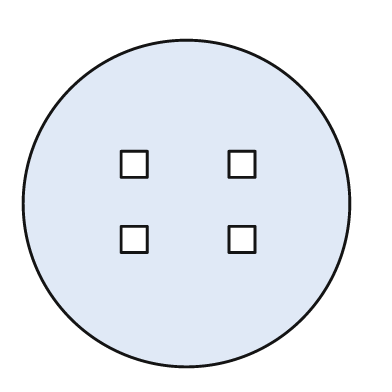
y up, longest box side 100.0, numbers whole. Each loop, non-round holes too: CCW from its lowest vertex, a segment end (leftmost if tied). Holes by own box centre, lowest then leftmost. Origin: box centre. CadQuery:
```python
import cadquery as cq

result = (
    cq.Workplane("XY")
    .moveTo(0.0, 0.0)
    .circle(50.0)
    .moveTo(-20.0, -15.0)
    .lineTo(-12.0, -15.0)
    .lineTo(-12.0, -7.0)
    .lineTo(-20.0, -7.0)
    .close()
    .moveTo(13.0, -15.0)
    .lineTo(21.0, -15.0)
    .lineTo(21.0, -7.0)
    .lineTo(13.0, -7.0)
    .close()
    .moveTo(-20.0, 8.0)
    .lineTo(-12.0, 8.0)
    .lineTo(-12.0, 16.0)
    .lineTo(-20.0, 16.0)
    .close()
    .moveTo(13.0, 8.0)
    .lineTo(21.0, 8.0)
    .lineTo(21.0, 16.0)
    .lineTo(13.0, 16.0)
    .close()
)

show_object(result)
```